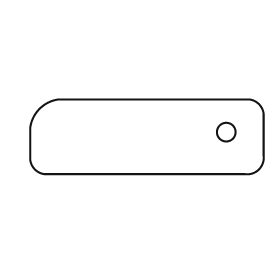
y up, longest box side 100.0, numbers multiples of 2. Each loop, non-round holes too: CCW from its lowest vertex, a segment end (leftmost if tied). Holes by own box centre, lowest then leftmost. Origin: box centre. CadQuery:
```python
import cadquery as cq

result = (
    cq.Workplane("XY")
    .moveTo(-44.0, -16.0)
    .lineTo(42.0, -16.0)
    .threePointArc((48.0, -14.0), (50.0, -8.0))
    .lineTo(50.0, 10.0)
    .threePointArc((48.0, 14.0), (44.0, 16.0))
    .lineTo(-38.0, 16.0)
    .threePointArc((-46.0, 12.0), (-50.0, 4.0))
    .lineTo(-50.0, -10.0)
    .threePointArc((-48.0, -14.0), (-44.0, -16.0))
    .close()
    .moveTo(34.0, 2.0)
    .circle(4.0)
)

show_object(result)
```